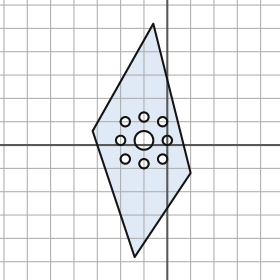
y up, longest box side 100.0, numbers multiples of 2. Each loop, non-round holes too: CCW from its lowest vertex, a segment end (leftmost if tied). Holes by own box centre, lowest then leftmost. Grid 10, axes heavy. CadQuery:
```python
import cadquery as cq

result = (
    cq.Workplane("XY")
    .moveTo(-14.0, -48.0)
    .lineTo(10.0, -12.0)
    .lineTo(-6.0, 52.0)
    .lineTo(-32.0, 6.0)
    .close()
    .moveTo(-10.0, -8.0)
    .circle(2.0)
    .moveTo(-18.0, -6.0)
    .circle(2.0)
    .moveTo(-2.0, -6.0)
    .circle(2.0)
    .moveTo(-20.0, 2.0)
    .circle(2.0)
    .moveTo(-10.0, 2.0)
    .circle(4.0)
    .moveTo(0.0, 2.0)
    .circle(2.0)
    .moveTo(-18.0, 10.0)
    .circle(2.0)
    .moveTo(-2.0, 10.0)
    .circle(2.0)
    .moveTo(-10.0, 12.0)
    .circle(2.0)
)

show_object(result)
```